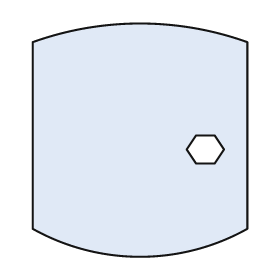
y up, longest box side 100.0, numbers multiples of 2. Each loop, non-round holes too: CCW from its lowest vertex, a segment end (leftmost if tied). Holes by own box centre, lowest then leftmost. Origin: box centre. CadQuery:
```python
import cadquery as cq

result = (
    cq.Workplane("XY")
    .moveTo(-46.0, -38.0)
    .threePointArc((0.0, -50.0), (46.0, -38.0))
    .lineTo(46.0, 42.0)
    .threePointArc((0.0, 50.0), (-46.0, 42.0))
    .close()
    .moveTo(24.0, -10.0)
    .lineTo(32.0, -10.0)
    .lineTo(36.0, -4.0)
    .lineTo(32.0, 2.0)
    .lineTo(24.0, 2.0)
    .lineTo(20.0, -4.0)
    .close()
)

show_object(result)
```